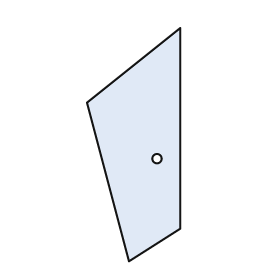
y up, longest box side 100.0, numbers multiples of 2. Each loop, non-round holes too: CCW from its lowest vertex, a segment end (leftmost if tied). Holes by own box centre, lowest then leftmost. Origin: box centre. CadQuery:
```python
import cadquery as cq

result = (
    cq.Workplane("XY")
    .moveTo(-2.0, -50.0)
    .lineTo(20.0, -36.0)
    .lineTo(20.0, 50.0)
    .lineTo(-20.0, 18.0)
    .close()
    .moveTo(10.0, -6.0)
    .circle(2.0)
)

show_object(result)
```